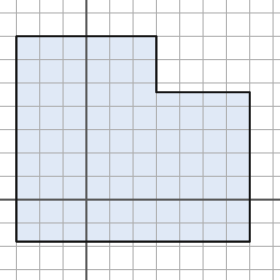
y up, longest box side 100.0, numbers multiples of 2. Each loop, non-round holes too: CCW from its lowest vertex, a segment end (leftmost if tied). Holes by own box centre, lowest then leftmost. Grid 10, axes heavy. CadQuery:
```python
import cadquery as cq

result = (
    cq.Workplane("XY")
    .moveTo(-30.0, -18.0)
    .lineTo(70.0, -18.0)
    .lineTo(70.0, 46.0)
    .lineTo(30.0, 46.0)
    .lineTo(30.0, 70.0)
    .lineTo(-30.0, 70.0)
    .close()
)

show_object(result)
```